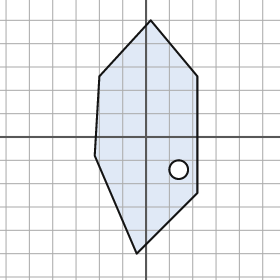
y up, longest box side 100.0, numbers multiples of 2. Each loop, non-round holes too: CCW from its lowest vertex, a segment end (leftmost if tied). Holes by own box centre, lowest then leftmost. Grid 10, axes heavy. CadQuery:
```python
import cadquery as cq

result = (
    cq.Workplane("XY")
    .moveTo(-4.0, -50.0)
    .lineTo(22.0, -24.0)
    .lineTo(22.0, 26.0)
    .lineTo(2.0, 50.0)
    .lineTo(-20.0, 26.0)
    .lineTo(-22.0, -8.0)
    .close()
    .moveTo(14.0, -14.0)
    .circle(4.0)
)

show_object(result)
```